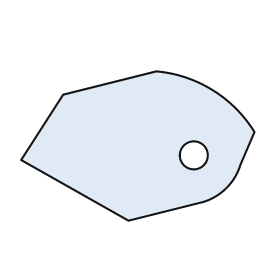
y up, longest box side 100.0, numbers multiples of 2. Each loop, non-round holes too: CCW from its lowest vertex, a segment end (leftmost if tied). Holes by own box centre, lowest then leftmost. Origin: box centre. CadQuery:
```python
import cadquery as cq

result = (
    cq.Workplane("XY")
    .moveTo(-4.0, -32.0)
    .lineTo(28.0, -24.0)
    .threePointArc((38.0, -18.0), (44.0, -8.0))
    .lineTo(50.0, 6.0)
    .threePointArc((32.0, 24.0), (8.0, 32.0))
    .lineTo(-32.0, 22.0)
    .lineTo(-50.0, -6.0)
    .close()
    .moveTo(24.0, -4.0)
    .circle(6.0)
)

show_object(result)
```